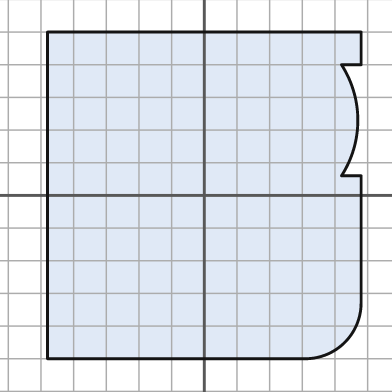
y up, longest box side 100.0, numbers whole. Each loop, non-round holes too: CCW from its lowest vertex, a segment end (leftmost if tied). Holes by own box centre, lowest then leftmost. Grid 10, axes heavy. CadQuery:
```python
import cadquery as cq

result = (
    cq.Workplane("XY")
    .moveTo(-48.0, -50.0)
    .lineTo(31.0, -50.0)
    .threePointArc((43.0, -45.0), (48.0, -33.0))
    .lineTo(48.0, 6.0)
    .lineTo(42.0, 6.0)
    .threePointArc((47.0, 23.0), (42.0, 40.0))
    .lineTo(48.0, 40.0)
    .lineTo(48.0, 50.0)
    .lineTo(-48.0, 50.0)
    .close()
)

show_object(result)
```